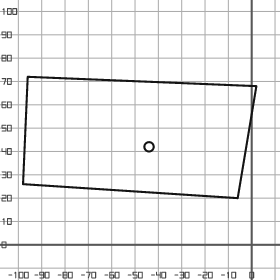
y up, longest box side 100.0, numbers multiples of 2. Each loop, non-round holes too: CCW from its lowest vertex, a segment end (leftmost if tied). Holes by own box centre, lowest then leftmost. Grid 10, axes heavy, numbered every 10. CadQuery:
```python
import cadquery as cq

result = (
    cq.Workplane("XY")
    .moveTo(-6.0, 20.0)
    .lineTo(2.0, 68.0)
    .lineTo(-96.0, 72.0)
    .lineTo(-98.0, 26.0)
    .close()
    .moveTo(-44.0, 42.0)
    .circle(2.0)
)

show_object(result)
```